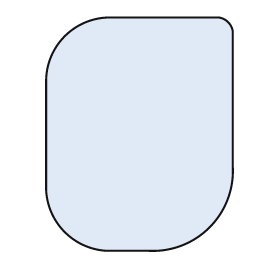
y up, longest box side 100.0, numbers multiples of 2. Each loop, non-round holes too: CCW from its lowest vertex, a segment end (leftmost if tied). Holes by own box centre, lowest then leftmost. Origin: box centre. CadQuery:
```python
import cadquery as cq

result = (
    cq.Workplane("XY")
    .moveTo(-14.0, -50.0)
    .lineTo(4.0, -50.0)
    .threePointArc((30.0, -40.0), (40.0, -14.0))
    .lineTo(40.0, 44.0)
    .threePointArc((38.0, 48.0), (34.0, 50.0))
    .lineTo(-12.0, 50.0)
    .threePointArc((-32.0, 42.0), (-40.0, 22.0))
    .lineTo(-40.0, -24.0)
    .threePointArc((-32.0, -42.0), (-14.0, -50.0))
    .close()
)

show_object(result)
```